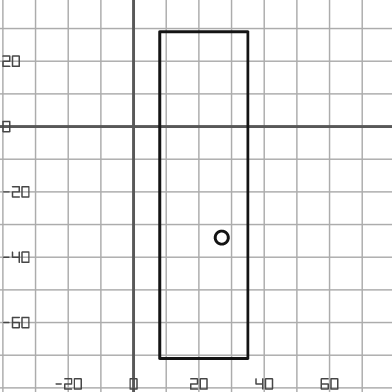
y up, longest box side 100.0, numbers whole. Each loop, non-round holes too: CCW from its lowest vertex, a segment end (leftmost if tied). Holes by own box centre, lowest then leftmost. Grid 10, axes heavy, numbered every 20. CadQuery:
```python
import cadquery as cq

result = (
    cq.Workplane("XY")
    .moveTo(8.0, -71.0)
    .lineTo(35.0, -71.0)
    .lineTo(35.0, 29.0)
    .lineTo(8.0, 29.0)
    .close()
    .moveTo(27.0, -34.0)
    .circle(2.0)
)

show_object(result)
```